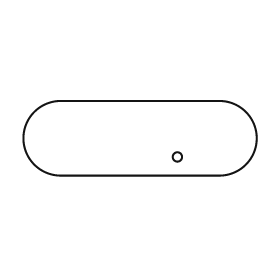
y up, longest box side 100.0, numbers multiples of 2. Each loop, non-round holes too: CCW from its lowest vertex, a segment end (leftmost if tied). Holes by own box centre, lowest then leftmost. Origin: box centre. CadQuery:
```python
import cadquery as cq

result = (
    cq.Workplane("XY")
    .moveTo(-34.0, -16.0)
    .lineTo(34.0, -16.0)
    .threePointArc((50.0, 0.0), (34.0, 16.0))
    .lineTo(-34.0, 16.0)
    .threePointArc((-50.0, 0.0), (-34.0, -16.0))
    .close()
    .moveTo(16.0, -8.0)
    .circle(2.0)
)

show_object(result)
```